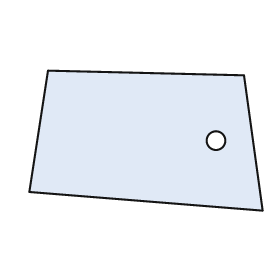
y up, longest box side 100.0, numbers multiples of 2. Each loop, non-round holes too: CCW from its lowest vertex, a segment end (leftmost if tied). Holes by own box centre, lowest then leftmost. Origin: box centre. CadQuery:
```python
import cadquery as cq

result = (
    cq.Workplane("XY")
    .moveTo(50.0, -30.0)
    .lineTo(42.0, 28.0)
    .lineTo(-42.0, 30.0)
    .lineTo(-50.0, -22.0)
    .close()
    .moveTo(30.0, 0.0)
    .circle(4.0)
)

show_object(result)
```